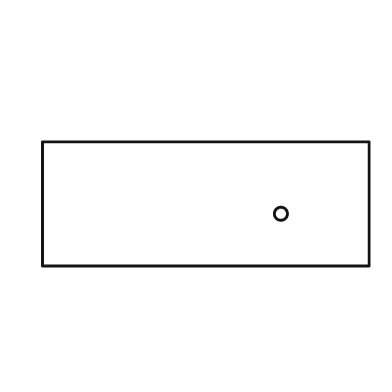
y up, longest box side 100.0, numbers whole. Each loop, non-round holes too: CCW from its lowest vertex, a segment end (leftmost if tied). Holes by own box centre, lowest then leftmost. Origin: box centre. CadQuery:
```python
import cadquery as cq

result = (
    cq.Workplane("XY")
    .moveTo(-50.0, -19.0)
    .lineTo(50.0, -19.0)
    .lineTo(50.0, 19.0)
    .lineTo(-50.0, 19.0)
    .close()
    .moveTo(23.0, -3.0)
    .circle(2.0)
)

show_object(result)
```